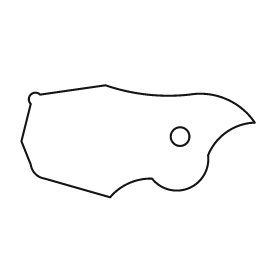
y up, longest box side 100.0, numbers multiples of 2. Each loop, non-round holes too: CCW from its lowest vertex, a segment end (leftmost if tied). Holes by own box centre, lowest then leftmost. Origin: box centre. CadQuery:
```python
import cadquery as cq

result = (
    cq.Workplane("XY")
    .moveTo(-12.0, -24.0)
    .threePointArc((-4.0, -18.0), (6.0, -16.0))
    .threePointArc((22.0, -20.0), (30.0, -6.0))
    .threePointArc((38.0, 4.0), (50.0, 8.0))
    .threePointArc((38.0, 18.0), (22.0, 20.0))
    .threePointArc((4.0, 20.0), (-14.0, 24.0))
    .lineTo(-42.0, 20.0)
    .threePointArc((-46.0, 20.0), (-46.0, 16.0))
    .lineTo(-50.0, 0.0)
    .lineTo(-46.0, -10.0)
    .threePointArc((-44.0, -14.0), (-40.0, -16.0))
    .close()
    .moveTo(18.0, 2.0)
    .circle(4.0)
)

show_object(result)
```